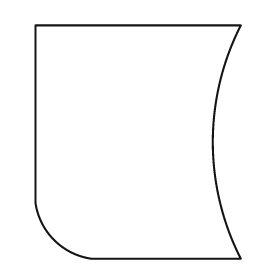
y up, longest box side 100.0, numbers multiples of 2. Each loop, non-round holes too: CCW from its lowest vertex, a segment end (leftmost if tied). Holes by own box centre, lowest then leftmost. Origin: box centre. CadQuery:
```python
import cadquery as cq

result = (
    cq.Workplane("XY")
    .moveTo(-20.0, -50.0)
    .lineTo(44.0, -50.0)
    .threePointArc((32.0, 0.0), (44.0, 50.0))
    .lineTo(-44.0, 50.0)
    .lineTo(-44.0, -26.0)
    .threePointArc((-36.0, -42.0), (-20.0, -50.0))
    .close()
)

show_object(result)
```